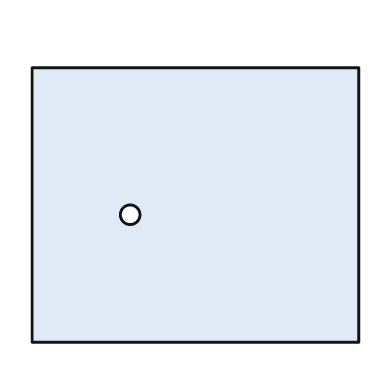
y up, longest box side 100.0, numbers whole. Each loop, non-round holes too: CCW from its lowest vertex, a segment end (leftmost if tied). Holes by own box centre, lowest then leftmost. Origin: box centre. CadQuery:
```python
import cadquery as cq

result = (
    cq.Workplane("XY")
    .moveTo(-50.0, -42.0)
    .lineTo(50.0, -42.0)
    .lineTo(50.0, 42.0)
    .lineTo(-50.0, 42.0)
    .close()
    .moveTo(-20.0, -3.0)
    .circle(3.0)
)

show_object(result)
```